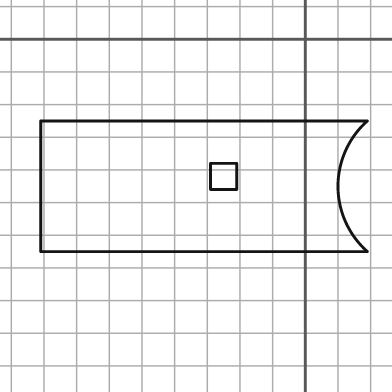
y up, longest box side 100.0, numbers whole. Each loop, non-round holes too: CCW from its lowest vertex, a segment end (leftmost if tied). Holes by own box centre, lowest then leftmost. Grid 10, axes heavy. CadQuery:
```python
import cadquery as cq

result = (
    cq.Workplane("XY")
    .moveTo(-81.0, -65.0)
    .lineTo(19.0, -65.0)
    .threePointArc((10.0, -45.0), (19.0, -25.0))
    .lineTo(-81.0, -25.0)
    .close()
    .moveTo(-29.0, -46.0)
    .lineTo(-21.0, -46.0)
    .lineTo(-21.0, -38.0)
    .lineTo(-29.0, -38.0)
    .close()
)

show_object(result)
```